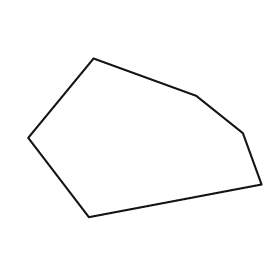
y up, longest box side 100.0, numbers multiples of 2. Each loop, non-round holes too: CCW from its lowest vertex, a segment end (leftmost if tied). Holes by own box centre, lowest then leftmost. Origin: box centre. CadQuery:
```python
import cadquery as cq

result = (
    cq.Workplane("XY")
    .moveTo(-24.0, -34.0)
    .lineTo(50.0, -20.0)
    .lineTo(42.0, 2.0)
    .lineTo(22.0, 18.0)
    .lineTo(-22.0, 34.0)
    .lineTo(-50.0, 0.0)
    .close()
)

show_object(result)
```